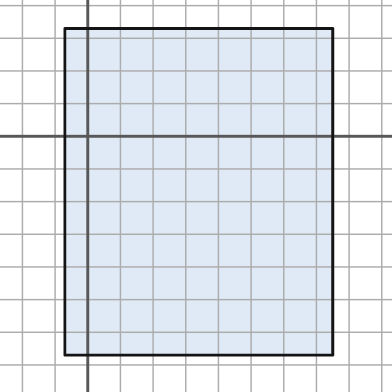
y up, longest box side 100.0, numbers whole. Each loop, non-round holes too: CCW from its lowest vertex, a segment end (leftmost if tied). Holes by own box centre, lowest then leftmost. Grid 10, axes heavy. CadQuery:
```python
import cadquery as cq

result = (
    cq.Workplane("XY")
    .moveTo(-7.0, -67.0)
    .lineTo(75.0, -67.0)
    .lineTo(75.0, 33.0)
    .lineTo(-7.0, 33.0)
    .close()
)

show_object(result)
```